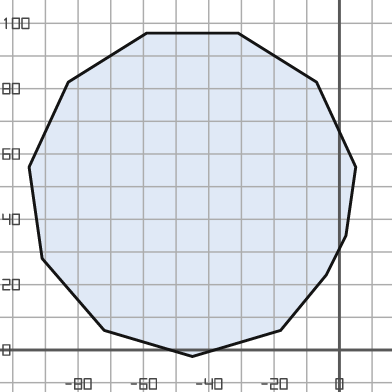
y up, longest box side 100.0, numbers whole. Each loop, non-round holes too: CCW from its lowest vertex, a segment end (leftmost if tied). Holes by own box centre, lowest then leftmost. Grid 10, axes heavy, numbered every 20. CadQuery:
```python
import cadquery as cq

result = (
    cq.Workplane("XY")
    .moveTo(-45.0, -2.0)
    .lineTo(-18.0, 6.0)
    .lineTo(-4.0, 23.0)
    .lineTo(2.0, 35.0)
    .lineTo(5.0, 56.0)
    .lineTo(-7.0, 82.0)
    .lineTo(-31.0, 97.0)
    .lineTo(-59.0, 97.0)
    .lineTo(-83.0, 82.0)
    .lineTo(-95.0, 56.0)
    .lineTo(-91.0, 28.0)
    .lineTo(-72.0, 6.0)
    .close()
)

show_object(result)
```